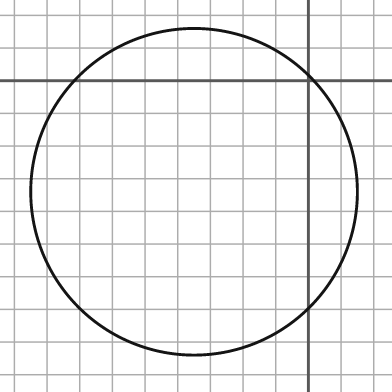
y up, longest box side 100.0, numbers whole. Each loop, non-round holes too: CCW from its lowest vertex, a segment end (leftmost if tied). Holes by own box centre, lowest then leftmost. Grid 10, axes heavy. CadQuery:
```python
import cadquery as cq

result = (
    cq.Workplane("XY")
    .moveTo(-35.0, -34.0)
    .circle(50.0)
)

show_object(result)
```